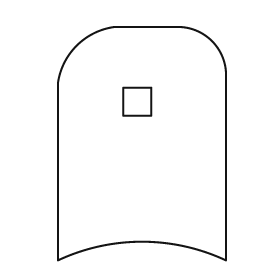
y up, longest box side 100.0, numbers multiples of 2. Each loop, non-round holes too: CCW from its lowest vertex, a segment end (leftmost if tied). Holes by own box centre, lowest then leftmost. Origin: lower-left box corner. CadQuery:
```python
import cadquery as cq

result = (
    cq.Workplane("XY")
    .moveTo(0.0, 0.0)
    .threePointArc((36.0, 8.0), (72.0, 0.0))
    .lineTo(72.0, 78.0)
    .threePointArc((66.0, 94.0), (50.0, 100.0))
    .lineTo(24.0, 100.0)
    .threePointArc((8.0, 92.0), (0.0, 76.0))
    .close()
    .moveTo(28.0, 62.0)
    .lineTo(40.0, 62.0)
    .lineTo(40.0, 74.0)
    .lineTo(28.0, 74.0)
    .close()
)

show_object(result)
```